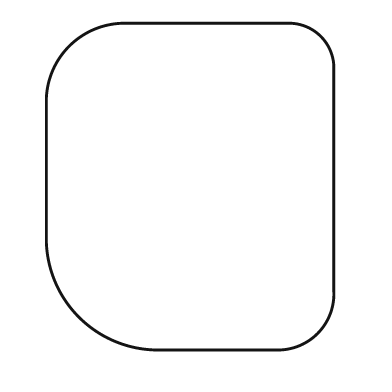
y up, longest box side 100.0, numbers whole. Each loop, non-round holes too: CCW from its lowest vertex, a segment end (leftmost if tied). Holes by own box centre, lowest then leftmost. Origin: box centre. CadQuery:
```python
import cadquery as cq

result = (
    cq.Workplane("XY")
    .moveTo(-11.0, -50.0)
    .lineTo(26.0, -50.0)
    .threePointArc((39.0, -45.0), (44.0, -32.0))
    .lineTo(44.0, 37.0)
    .threePointArc((40.0, 46.0), (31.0, 50.0))
    .lineTo(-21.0, 50.0)
    .threePointArc((-37.0, 43.0), (-44.0, 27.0))
    .lineTo(-44.0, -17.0)
    .threePointArc((-34.0, -40.0), (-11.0, -50.0))
    .close()
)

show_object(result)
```